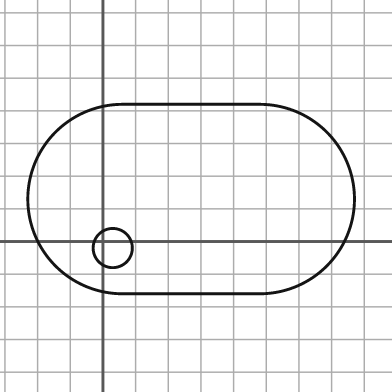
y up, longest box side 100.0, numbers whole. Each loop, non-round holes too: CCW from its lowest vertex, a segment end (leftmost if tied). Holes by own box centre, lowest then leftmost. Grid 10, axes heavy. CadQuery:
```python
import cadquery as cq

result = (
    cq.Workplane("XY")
    .moveTo(6.0, -16.0)
    .lineTo(48.0, -16.0)
    .threePointArc((77.0, 13.0), (48.0, 42.0))
    .lineTo(6.0, 42.0)
    .threePointArc((-23.0, 13.0), (6.0, -16.0))
    .close()
    .moveTo(3.0, -2.0)
    .circle(6.0)
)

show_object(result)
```